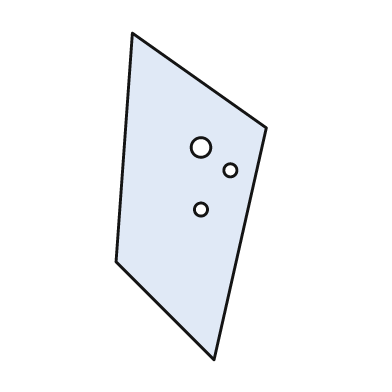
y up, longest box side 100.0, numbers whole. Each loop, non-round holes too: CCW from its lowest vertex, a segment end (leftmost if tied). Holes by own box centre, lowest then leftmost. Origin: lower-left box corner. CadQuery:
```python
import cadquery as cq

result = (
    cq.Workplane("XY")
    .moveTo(30.0, 0.0)
    .lineTo(46.0, 71.0)
    .lineTo(5.0, 100.0)
    .lineTo(0.0, 30.0)
    .close()
    .moveTo(26.0, 46.0)
    .circle(2.0)
    .moveTo(35.0, 58.0)
    .circle(2.0)
    .moveTo(26.0, 65.0)
    .circle(3.0)
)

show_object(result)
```